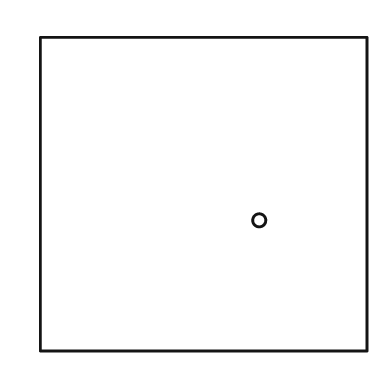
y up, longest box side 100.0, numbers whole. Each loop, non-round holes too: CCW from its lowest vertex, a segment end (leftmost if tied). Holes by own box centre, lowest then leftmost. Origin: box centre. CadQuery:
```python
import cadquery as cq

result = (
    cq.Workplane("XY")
    .moveTo(-50.0, -48.0)
    .lineTo(50.0, -48.0)
    .lineTo(50.0, 48.0)
    .lineTo(-50.0, 48.0)
    .close()
    .moveTo(17.0, -8.0)
    .circle(2.0)
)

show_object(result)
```